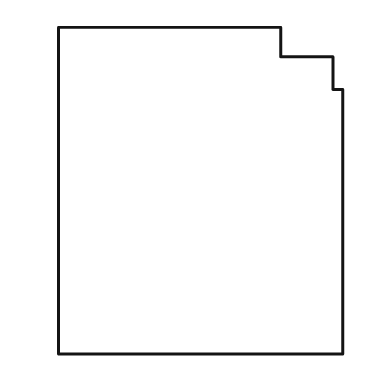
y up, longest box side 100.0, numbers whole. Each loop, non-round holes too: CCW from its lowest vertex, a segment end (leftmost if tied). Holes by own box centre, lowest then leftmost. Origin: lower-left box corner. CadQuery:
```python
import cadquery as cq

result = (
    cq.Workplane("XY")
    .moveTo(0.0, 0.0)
    .lineTo(87.0, 0.0)
    .lineTo(87.0, 81.0)
    .lineTo(84.0, 81.0)
    .lineTo(84.0, 91.0)
    .lineTo(68.0, 91.0)
    .lineTo(68.0, 100.0)
    .lineTo(0.0, 100.0)
    .close()
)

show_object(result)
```